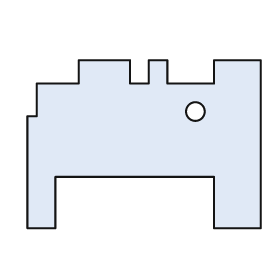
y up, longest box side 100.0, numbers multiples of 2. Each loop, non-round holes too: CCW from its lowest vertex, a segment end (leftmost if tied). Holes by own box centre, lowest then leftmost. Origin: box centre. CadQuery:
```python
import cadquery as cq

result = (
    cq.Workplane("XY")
    .moveTo(-50.0, -36.0)
    .lineTo(-38.0, -36.0)
    .lineTo(-38.0, -14.0)
    .lineTo(30.0, -14.0)
    .lineTo(30.0, -36.0)
    .lineTo(50.0, -36.0)
    .lineTo(50.0, 36.0)
    .lineTo(30.0, 36.0)
    .lineTo(30.0, 26.0)
    .lineTo(10.0, 26.0)
    .lineTo(10.0, 36.0)
    .lineTo(2.0, 36.0)
    .lineTo(2.0, 26.0)
    .lineTo(-6.0, 26.0)
    .lineTo(-6.0, 36.0)
    .lineTo(-28.0, 36.0)
    .lineTo(-28.0, 26.0)
    .lineTo(-46.0, 26.0)
    .lineTo(-46.0, 12.0)
    .lineTo(-50.0, 12.0)
    .close()
    .moveTo(22.0, 14.0)
    .circle(4.0)
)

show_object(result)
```